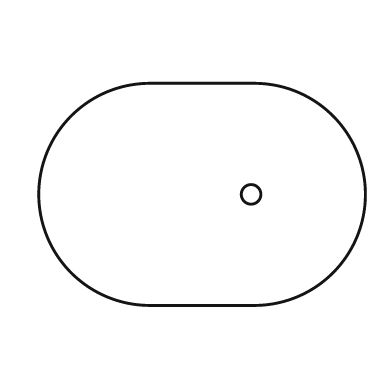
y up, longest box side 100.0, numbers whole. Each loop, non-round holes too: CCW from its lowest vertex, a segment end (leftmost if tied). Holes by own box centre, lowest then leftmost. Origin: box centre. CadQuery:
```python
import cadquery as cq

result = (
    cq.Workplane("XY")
    .moveTo(-16.0, -34.0)
    .lineTo(16.0, -34.0)
    .threePointArc((50.0, 0.0), (16.0, 34.0))
    .lineTo(-16.0, 34.0)
    .threePointArc((-50.0, 0.0), (-16.0, -34.0))
    .close()
    .moveTo(15.0, 0.0)
    .circle(3.0)
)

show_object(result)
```